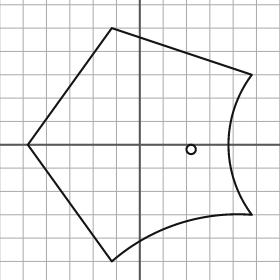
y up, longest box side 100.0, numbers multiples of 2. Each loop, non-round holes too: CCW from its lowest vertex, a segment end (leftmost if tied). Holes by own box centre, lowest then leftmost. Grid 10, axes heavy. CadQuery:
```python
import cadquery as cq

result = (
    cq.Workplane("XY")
    .moveTo(-12.0, -50.0)
    .threePointArc((16.0, -34.0), (48.0, -30.0))
    .threePointArc((38.0, 0.0), (48.0, 30.0))
    .lineTo(-12.0, 50.0)
    .lineTo(-48.0, 0.0)
    .close()
    .moveTo(22.0, -2.0)
    .circle(2.0)
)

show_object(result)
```